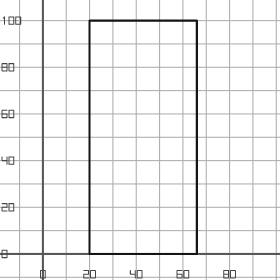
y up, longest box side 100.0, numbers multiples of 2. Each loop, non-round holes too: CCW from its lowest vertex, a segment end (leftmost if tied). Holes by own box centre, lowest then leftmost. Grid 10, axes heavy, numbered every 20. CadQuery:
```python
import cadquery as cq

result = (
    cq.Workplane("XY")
    .moveTo(20.0, 0.0)
    .lineTo(66.0, 0.0)
    .lineTo(66.0, 100.0)
    .lineTo(20.0, 100.0)
    .close()
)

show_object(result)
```